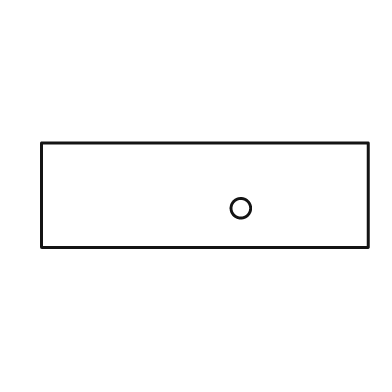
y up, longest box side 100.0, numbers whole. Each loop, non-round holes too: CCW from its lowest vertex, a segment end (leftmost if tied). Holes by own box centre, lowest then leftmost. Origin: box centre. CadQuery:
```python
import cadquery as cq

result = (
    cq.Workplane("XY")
    .moveTo(-50.0, -16.0)
    .lineTo(50.0, -16.0)
    .lineTo(50.0, 16.0)
    .lineTo(-50.0, 16.0)
    .close()
    .moveTo(11.0, -4.0)
    .circle(3.0)
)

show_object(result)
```